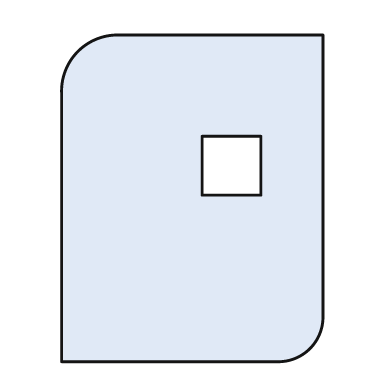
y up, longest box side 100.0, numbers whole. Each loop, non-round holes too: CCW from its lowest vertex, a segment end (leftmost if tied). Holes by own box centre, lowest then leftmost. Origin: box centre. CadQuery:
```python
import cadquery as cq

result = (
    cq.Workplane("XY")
    .moveTo(-40.0, -50.0)
    .lineTo(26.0, -50.0)
    .threePointArc((36.0, -46.0), (40.0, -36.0))
    .lineTo(40.0, 50.0)
    .lineTo(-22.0, 50.0)
    .threePointArc((-35.0, 45.0), (-40.0, 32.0))
    .close()
    .moveTo(3.0, 1.0)
    .lineTo(21.0, 1.0)
    .lineTo(21.0, 19.0)
    .lineTo(3.0, 19.0)
    .close()
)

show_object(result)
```